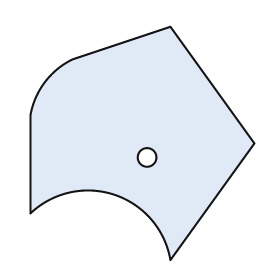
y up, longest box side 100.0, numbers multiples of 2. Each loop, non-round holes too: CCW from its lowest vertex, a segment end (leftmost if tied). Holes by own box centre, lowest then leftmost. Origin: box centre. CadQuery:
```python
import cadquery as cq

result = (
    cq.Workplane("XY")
    .moveTo(12.0, -50.0)
    .lineTo(48.0, 0.0)
    .lineTo(12.0, 50.0)
    .lineTo(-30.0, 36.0)
    .threePointArc((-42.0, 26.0), (-48.0, 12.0))
    .lineTo(-48.0, -30.0)
    .threePointArc((-12.0, -22.0), (12.0, -50.0))
    .close()
    .moveTo(2.0, -6.0)
    .circle(4.0)
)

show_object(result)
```